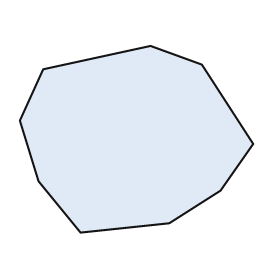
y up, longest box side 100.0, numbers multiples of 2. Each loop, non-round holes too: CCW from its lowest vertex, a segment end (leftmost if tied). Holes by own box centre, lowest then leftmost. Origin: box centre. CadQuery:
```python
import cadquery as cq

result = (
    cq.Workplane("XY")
    .moveTo(-24.0, -40.0)
    .lineTo(14.0, -36.0)
    .lineTo(36.0, -22.0)
    .lineTo(50.0, -2.0)
    .lineTo(28.0, 32.0)
    .lineTo(6.0, 40.0)
    .lineTo(-40.0, 30.0)
    .lineTo(-50.0, 8.0)
    .lineTo(-42.0, -18.0)
    .close()
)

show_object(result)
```